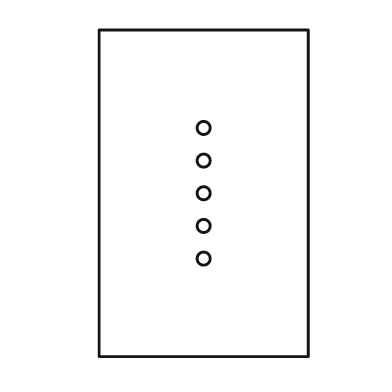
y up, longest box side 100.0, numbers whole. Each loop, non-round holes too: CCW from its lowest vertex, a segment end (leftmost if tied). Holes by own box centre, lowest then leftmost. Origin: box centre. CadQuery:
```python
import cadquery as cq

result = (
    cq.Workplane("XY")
    .moveTo(-32.0, -50.0)
    .lineTo(32.0, -50.0)
    .lineTo(32.0, 50.0)
    .lineTo(-32.0, 50.0)
    .close()
    .moveTo(0.0, -20.0)
    .circle(2.0)
    .moveTo(0.0, -10.0)
    .circle(2.0)
    .moveTo(0.0, 0.0)
    .circle(2.0)
    .moveTo(0.0, 10.0)
    .circle(2.0)
    .moveTo(0.0, 20.0)
    .circle(2.0)
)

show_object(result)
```